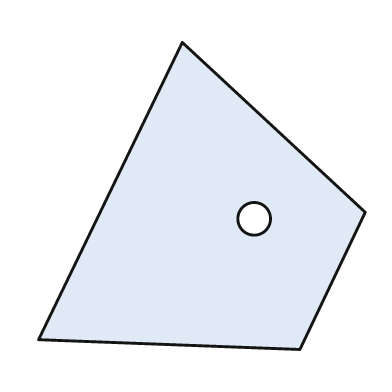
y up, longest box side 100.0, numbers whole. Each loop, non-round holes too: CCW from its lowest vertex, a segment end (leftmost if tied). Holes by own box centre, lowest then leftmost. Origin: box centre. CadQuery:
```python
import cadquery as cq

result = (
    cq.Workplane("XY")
    .moveTo(30.0, -47.0)
    .lineTo(50.0, -5.0)
    .lineTo(-6.0, 47.0)
    .lineTo(-50.0, -44.0)
    .close()
    .moveTo(16.0, -7.0)
    .circle(5.0)
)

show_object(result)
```